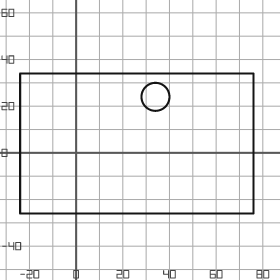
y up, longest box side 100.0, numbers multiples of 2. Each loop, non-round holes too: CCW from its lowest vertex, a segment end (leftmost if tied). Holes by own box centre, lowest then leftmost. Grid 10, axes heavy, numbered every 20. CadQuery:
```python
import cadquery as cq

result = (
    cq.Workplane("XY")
    .moveTo(-24.0, -26.0)
    .lineTo(76.0, -26.0)
    .lineTo(76.0, 34.0)
    .lineTo(-24.0, 34.0)
    .close()
    .moveTo(34.0, 24.0)
    .circle(6.0)
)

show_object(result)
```